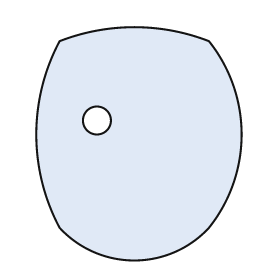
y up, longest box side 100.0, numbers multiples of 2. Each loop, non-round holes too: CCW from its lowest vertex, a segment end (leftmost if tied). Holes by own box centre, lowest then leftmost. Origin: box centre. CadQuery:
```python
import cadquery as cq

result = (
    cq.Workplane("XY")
    .moveTo(-34.0, -36.0)
    .threePointArc((-2.0, -50.0), (30.0, -36.0))
    .threePointArc((44.0, 4.0), (30.0, 44.0))
    .threePointArc((-2.0, 50.0), (-34.0, 44.0))
    .threePointArc((-44.0, 4.0), (-34.0, -36.0))
    .close()
    .moveTo(-18.0, 10.0)
    .circle(6.0)
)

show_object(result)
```